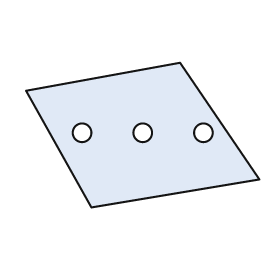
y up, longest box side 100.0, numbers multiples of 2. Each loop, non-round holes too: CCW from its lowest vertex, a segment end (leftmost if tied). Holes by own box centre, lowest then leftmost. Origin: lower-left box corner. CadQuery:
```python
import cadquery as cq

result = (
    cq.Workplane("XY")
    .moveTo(28.0, 0.0)
    .lineTo(100.0, 12.0)
    .lineTo(66.0, 62.0)
    .lineTo(0.0, 50.0)
    .close()
    .moveTo(24.0, 32.0)
    .circle(4.0)
    .moveTo(50.0, 32.0)
    .circle(4.0)
    .moveTo(76.0, 32.0)
    .circle(4.0)
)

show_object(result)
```